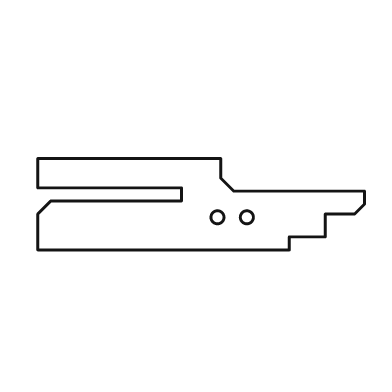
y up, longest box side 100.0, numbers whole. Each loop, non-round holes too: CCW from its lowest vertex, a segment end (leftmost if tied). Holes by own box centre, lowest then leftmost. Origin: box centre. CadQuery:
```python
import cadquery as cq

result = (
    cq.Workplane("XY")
    .moveTo(-50.0, -14.0)
    .lineTo(27.0, -14.0)
    .lineTo(27.0, -10.0)
    .lineTo(38.0, -10.0)
    .lineTo(38.0, -3.0)
    .lineTo(47.0, -3.0)
    .lineTo(50.0, 0.0)
    .lineTo(50.0, 4.0)
    .lineTo(10.0, 4.0)
    .lineTo(6.0, 8.0)
    .lineTo(6.0, 14.0)
    .lineTo(-50.0, 14.0)
    .lineTo(-50.0, 5.0)
    .lineTo(-6.0, 5.0)
    .lineTo(-6.0, 1.0)
    .lineTo(-46.0, 1.0)
    .lineTo(-50.0, -3.0)
    .close()
    .moveTo(5.0, -4.0)
    .circle(2.0)
    .moveTo(14.0, -4.0)
    .circle(2.0)
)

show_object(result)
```